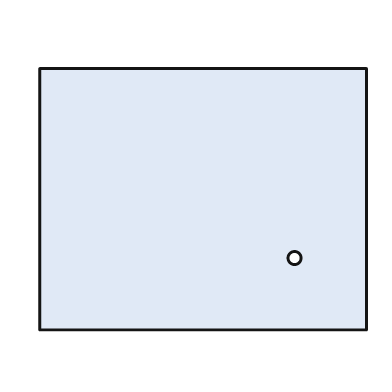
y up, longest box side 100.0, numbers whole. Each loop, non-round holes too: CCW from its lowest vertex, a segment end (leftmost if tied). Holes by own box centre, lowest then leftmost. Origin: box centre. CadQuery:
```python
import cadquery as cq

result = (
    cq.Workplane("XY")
    .moveTo(-50.0, -40.0)
    .lineTo(50.0, -40.0)
    .lineTo(50.0, 40.0)
    .lineTo(-50.0, 40.0)
    .close()
    .moveTo(28.0, -18.0)
    .circle(2.0)
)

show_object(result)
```